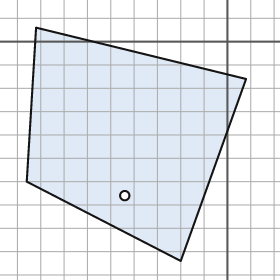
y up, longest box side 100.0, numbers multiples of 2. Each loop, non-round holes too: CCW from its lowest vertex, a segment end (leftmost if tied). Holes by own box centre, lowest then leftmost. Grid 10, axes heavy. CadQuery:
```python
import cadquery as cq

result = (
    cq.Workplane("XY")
    .moveTo(-20.0, -94.0)
    .lineTo(8.0, -16.0)
    .lineTo(-82.0, 6.0)
    .lineTo(-86.0, -60.0)
    .close()
    .moveTo(-44.0, -66.0)
    .circle(2.0)
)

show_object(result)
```